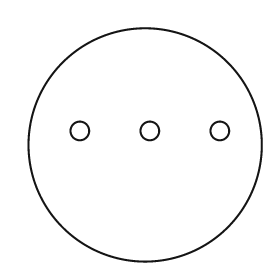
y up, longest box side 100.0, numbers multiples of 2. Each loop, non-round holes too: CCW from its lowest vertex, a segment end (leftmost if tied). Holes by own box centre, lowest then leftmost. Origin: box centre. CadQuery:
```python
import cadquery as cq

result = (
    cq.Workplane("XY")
    .moveTo(0.0, 0.0)
    .circle(50.0)
    .moveTo(-28.0, 6.0)
    .circle(4.0)
    .moveTo(2.0, 6.0)
    .circle(4.0)
    .moveTo(32.0, 6.0)
    .circle(4.0)
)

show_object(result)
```